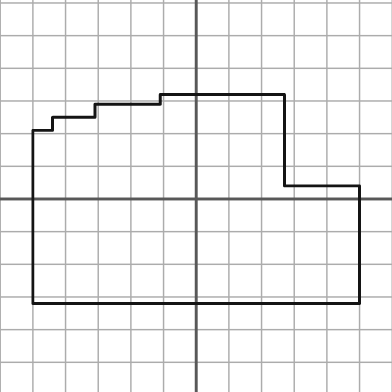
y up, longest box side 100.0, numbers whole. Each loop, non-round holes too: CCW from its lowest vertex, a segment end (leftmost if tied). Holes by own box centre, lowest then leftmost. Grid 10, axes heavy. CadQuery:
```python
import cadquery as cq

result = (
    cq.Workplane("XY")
    .moveTo(-50.0, -32.0)
    .lineTo(50.0, -32.0)
    .lineTo(50.0, 4.0)
    .lineTo(27.0, 4.0)
    .lineTo(27.0, 32.0)
    .lineTo(-11.0, 32.0)
    .lineTo(-11.0, 29.0)
    .lineTo(-31.0, 29.0)
    .lineTo(-31.0, 25.0)
    .lineTo(-44.0, 25.0)
    .lineTo(-44.0, 21.0)
    .lineTo(-50.0, 21.0)
    .close()
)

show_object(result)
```